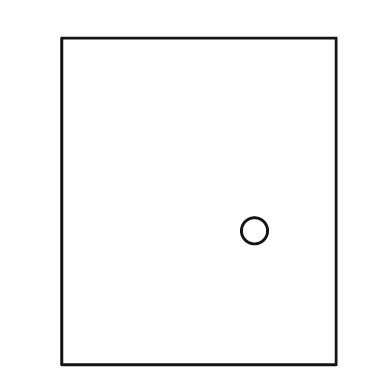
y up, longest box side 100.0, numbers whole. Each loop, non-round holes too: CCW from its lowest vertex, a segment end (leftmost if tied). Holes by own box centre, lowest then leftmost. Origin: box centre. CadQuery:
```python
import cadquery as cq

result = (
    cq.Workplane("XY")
    .moveTo(-42.0, -50.0)
    .lineTo(42.0, -50.0)
    .lineTo(42.0, 50.0)
    .lineTo(-42.0, 50.0)
    .close()
    .moveTo(17.0, -9.0)
    .circle(4.0)
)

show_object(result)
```